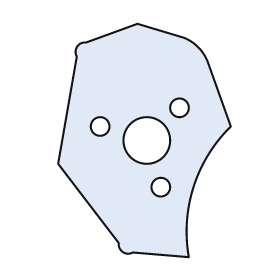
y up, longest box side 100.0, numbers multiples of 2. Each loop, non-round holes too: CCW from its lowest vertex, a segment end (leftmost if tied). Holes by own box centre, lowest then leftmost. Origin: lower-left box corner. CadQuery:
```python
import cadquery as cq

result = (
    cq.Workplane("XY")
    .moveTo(56.0, 0.0)
    .threePointArc((58.0, 30.0), (74.0, 56.0))
    .lineTo(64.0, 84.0)
    .threePointArc((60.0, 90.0), (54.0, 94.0))
    .lineTo(34.0, 100.0)
    .lineTo(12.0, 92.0)
    .threePointArc((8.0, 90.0), (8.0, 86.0))
    .lineTo(0.0, 40.0)
    .lineTo(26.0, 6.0)
    .threePointArc((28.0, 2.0), (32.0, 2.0))
    .close()
    .moveTo(44.0, 30.0)
    .circle(4.0)
    .moveTo(38.0, 50.0)
    .circle(10.0)
    .moveTo(18.0, 56.0)
    .circle(4.0)
    .moveTo(52.0, 64.0)
    .circle(4.0)
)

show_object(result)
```